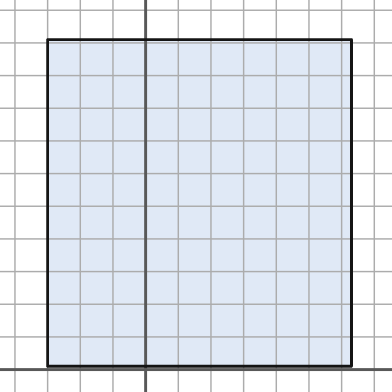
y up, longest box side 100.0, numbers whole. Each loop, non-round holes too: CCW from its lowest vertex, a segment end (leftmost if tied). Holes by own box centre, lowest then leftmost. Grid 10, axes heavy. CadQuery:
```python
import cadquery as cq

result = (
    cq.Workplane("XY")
    .moveTo(-30.0, 1.0)
    .lineTo(63.0, 1.0)
    .lineTo(63.0, 101.0)
    .lineTo(-30.0, 101.0)
    .close()
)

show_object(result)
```